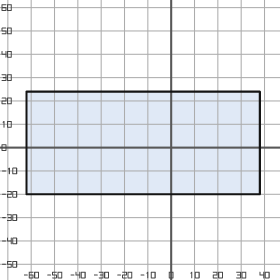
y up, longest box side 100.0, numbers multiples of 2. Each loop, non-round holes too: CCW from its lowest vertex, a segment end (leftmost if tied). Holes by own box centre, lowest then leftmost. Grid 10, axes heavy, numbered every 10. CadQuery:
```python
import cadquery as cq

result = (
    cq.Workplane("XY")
    .moveTo(-62.0, -20.0)
    .lineTo(38.0, -20.0)
    .lineTo(38.0, 24.0)
    .lineTo(-62.0, 24.0)
    .close()
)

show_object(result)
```